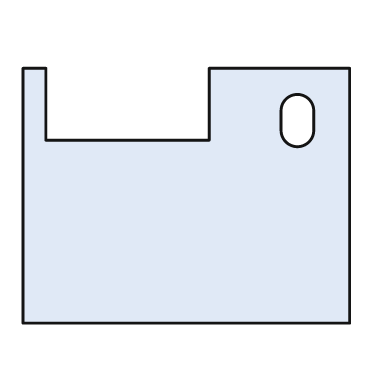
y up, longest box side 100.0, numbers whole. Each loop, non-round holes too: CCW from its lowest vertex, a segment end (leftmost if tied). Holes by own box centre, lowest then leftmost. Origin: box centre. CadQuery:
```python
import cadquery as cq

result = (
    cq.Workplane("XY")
    .moveTo(-50.0, -39.0)
    .lineTo(50.0, -39.0)
    .lineTo(50.0, 39.0)
    .lineTo(7.0, 39.0)
    .lineTo(7.0, 17.0)
    .lineTo(-43.0, 17.0)
    .lineTo(-43.0, 39.0)
    .lineTo(-50.0, 39.0)
    .close()
    .moveTo(29.0, 20.0)
    .threePointArc((34.0, 15.0), (39.0, 20.0))
    .lineTo(39.0, 26.0)
    .threePointArc((34.0, 31.0), (29.0, 26.0))
    .close()
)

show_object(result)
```